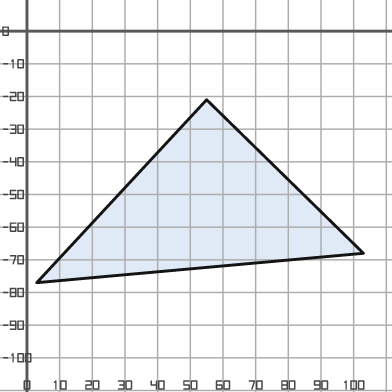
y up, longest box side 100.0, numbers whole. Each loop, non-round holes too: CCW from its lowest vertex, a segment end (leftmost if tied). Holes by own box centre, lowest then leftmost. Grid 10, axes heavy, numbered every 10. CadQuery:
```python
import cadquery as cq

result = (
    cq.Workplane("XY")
    .moveTo(3.0, -77.0)
    .lineTo(103.0, -68.0)
    .lineTo(55.0, -21.0)
    .close()
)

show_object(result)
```